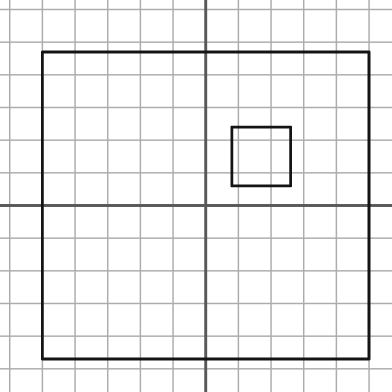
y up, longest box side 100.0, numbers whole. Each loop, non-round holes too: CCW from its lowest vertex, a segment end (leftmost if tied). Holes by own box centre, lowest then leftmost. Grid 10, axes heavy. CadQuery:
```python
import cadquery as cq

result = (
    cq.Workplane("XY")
    .moveTo(-50.0, -47.0)
    .lineTo(50.0, -47.0)
    .lineTo(50.0, 47.0)
    .lineTo(-50.0, 47.0)
    .close()
    .moveTo(8.0, 6.0)
    .lineTo(26.0, 6.0)
    .lineTo(26.0, 24.0)
    .lineTo(8.0, 24.0)
    .close()
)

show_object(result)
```